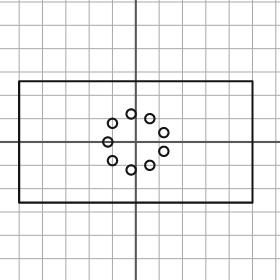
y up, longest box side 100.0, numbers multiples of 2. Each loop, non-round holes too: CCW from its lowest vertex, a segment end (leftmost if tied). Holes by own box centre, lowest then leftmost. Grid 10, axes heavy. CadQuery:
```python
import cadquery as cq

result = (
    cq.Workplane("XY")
    .moveTo(-50.0, -26.0)
    .lineTo(50.0, -26.0)
    .lineTo(50.0, 26.0)
    .lineTo(-50.0, 26.0)
    .close()
    .moveTo(-2.0, -12.0)
    .circle(2.0)
    .moveTo(6.0, -10.0)
    .circle(2.0)
    .moveTo(-10.0, -8.0)
    .circle(2.0)
    .moveTo(12.0, -4.0)
    .circle(2.0)
    .moveTo(-12.0, 0.0)
    .circle(2.0)
    .moveTo(12.0, 4.0)
    .circle(2.0)
    .moveTo(-10.0, 8.0)
    .circle(2.0)
    .moveTo(6.0, 10.0)
    .circle(2.0)
    .moveTo(-2.0, 12.0)
    .circle(2.0)
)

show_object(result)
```